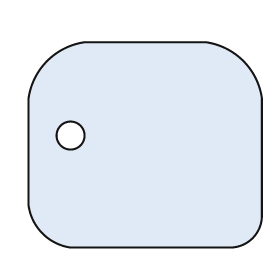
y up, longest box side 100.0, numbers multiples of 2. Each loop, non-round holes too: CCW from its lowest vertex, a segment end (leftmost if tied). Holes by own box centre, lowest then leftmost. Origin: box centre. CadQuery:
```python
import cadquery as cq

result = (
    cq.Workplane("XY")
    .moveTo(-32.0, -44.0)
    .lineTo(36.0, -44.0)
    .threePointArc((46.0, -40.0), (50.0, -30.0))
    .lineTo(50.0, 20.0)
    .threePointArc((42.0, 36.0), (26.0, 44.0))
    .lineTo(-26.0, 44.0)
    .threePointArc((-42.0, 36.0), (-50.0, 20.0))
    .lineTo(-50.0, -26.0)
    .threePointArc((-44.0, -38.0), (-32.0, -44.0))
    .close()
    .moveTo(-32.0, 4.0)
    .circle(6.0)
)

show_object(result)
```